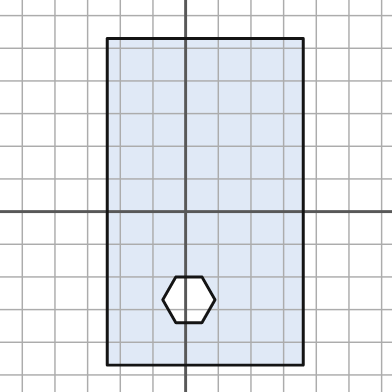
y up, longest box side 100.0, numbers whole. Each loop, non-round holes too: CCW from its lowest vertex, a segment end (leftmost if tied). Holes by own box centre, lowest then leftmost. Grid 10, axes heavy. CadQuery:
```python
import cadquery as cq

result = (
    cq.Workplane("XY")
    .moveTo(-24.0, -47.0)
    .lineTo(36.0, -47.0)
    .lineTo(36.0, 53.0)
    .lineTo(-24.0, 53.0)
    .close()
    .moveTo(-3.0, -34.0)
    .lineTo(5.0, -34.0)
    .lineTo(9.0, -27.0)
    .lineTo(5.0, -20.0)
    .lineTo(-3.0, -20.0)
    .lineTo(-7.0, -27.0)
    .close()
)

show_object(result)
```